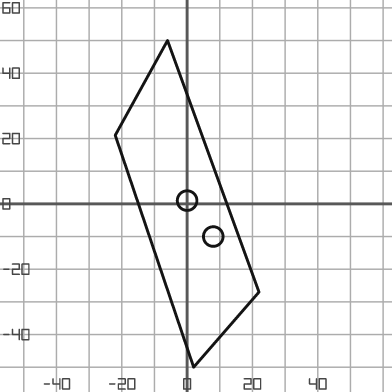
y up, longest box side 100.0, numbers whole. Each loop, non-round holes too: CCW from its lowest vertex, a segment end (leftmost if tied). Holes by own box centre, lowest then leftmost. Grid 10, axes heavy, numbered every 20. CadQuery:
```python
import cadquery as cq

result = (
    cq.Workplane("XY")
    .moveTo(2.0, -50.0)
    .lineTo(22.0, -27.0)
    .lineTo(-6.0, 50.0)
    .lineTo(-22.0, 21.0)
    .close()
    .moveTo(8.0, -10.0)
    .circle(3.0)
    .moveTo(0.0, 1.0)
    .circle(3.0)
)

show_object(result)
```